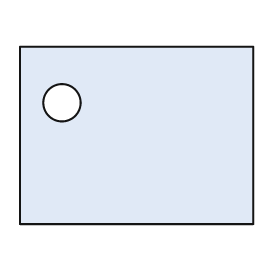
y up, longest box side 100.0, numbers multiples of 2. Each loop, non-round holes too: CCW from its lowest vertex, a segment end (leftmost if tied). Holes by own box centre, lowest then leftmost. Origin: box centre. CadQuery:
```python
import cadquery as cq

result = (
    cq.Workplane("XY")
    .moveTo(-50.0, -38.0)
    .lineTo(50.0, -38.0)
    .lineTo(50.0, 38.0)
    .lineTo(-50.0, 38.0)
    .close()
    .moveTo(-32.0, 14.0)
    .circle(8.0)
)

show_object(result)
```